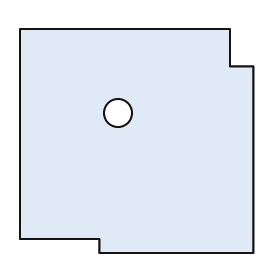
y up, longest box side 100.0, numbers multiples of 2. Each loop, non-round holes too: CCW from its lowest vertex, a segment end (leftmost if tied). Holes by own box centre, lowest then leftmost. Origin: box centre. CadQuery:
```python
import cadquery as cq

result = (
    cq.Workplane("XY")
    .moveTo(-16.0, -48.0)
    .lineTo(50.0, -48.0)
    .lineTo(50.0, 32.0)
    .lineTo(40.0, 32.0)
    .lineTo(40.0, 48.0)
    .lineTo(-50.0, 48.0)
    .lineTo(-50.0, -42.0)
    .lineTo(-16.0, -42.0)
    .close()
    .moveTo(-8.0, 12.0)
    .circle(6.0)
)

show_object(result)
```